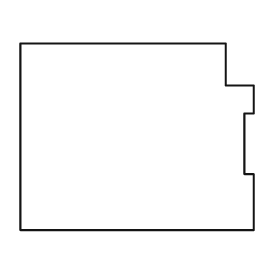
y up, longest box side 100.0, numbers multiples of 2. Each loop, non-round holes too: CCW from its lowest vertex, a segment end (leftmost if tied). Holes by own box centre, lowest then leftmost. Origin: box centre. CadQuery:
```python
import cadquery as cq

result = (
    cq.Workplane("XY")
    .moveTo(-50.0, -40.0)
    .lineTo(50.0, -40.0)
    .lineTo(50.0, -16.0)
    .lineTo(46.0, -16.0)
    .lineTo(46.0, 10.0)
    .lineTo(50.0, 10.0)
    .lineTo(50.0, 22.0)
    .lineTo(38.0, 22.0)
    .lineTo(38.0, 40.0)
    .lineTo(-50.0, 40.0)
    .close()
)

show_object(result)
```